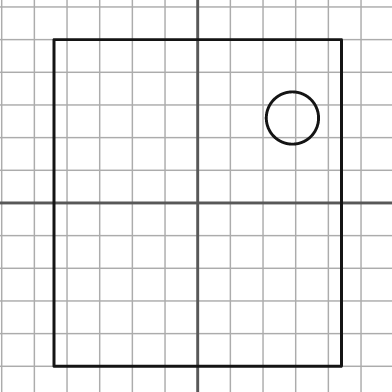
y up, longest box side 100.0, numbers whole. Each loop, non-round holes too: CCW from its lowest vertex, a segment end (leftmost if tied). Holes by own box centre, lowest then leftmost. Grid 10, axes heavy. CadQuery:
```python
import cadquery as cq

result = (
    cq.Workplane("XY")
    .moveTo(-44.0, -50.0)
    .lineTo(44.0, -50.0)
    .lineTo(44.0, 50.0)
    .lineTo(-44.0, 50.0)
    .close()
    .moveTo(29.0, 26.0)
    .circle(8.0)
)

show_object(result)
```